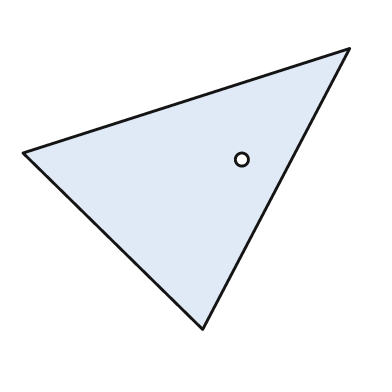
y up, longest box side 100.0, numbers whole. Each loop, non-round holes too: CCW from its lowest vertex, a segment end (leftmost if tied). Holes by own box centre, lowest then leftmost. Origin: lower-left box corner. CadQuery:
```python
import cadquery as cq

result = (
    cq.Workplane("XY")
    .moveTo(55.0, 0.0)
    .lineTo(100.0, 86.0)
    .lineTo(0.0, 54.0)
    .close()
    .moveTo(67.0, 52.0)
    .circle(2.0)
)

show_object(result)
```